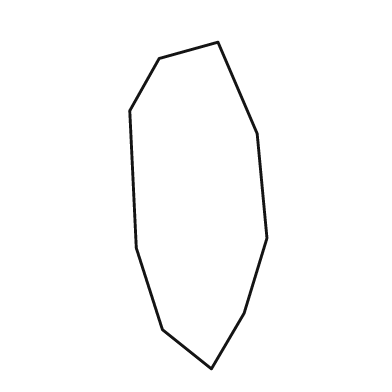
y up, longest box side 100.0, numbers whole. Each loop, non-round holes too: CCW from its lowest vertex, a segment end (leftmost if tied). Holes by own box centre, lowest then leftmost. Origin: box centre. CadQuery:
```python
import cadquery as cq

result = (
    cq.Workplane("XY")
    .moveTo(4.0, -50.0)
    .lineTo(14.0, -33.0)
    .lineTo(21.0, -10.0)
    .lineTo(18.0, 22.0)
    .lineTo(6.0, 50.0)
    .lineTo(-12.0, 45.0)
    .lineTo(-21.0, 29.0)
    .lineTo(-19.0, -13.0)
    .lineTo(-11.0, -38.0)
    .close()
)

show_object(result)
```